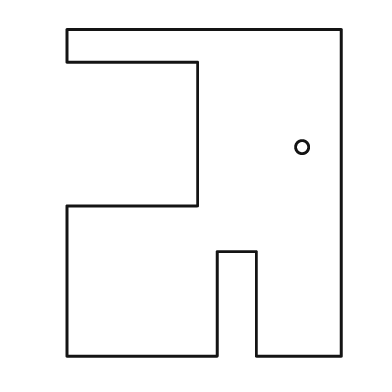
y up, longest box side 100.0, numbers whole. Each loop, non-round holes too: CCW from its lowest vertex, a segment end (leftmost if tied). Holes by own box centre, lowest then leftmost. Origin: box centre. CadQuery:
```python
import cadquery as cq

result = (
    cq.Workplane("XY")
    .moveTo(-42.0, -50.0)
    .lineTo(4.0, -50.0)
    .lineTo(4.0, -18.0)
    .lineTo(16.0, -18.0)
    .lineTo(16.0, -50.0)
    .lineTo(42.0, -50.0)
    .lineTo(42.0, 50.0)
    .lineTo(-42.0, 50.0)
    .lineTo(-42.0, 40.0)
    .lineTo(-2.0, 40.0)
    .lineTo(-2.0, -4.0)
    .lineTo(-42.0, -4.0)
    .close()
    .moveTo(30.0, 14.0)
    .circle(2.0)
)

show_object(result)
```